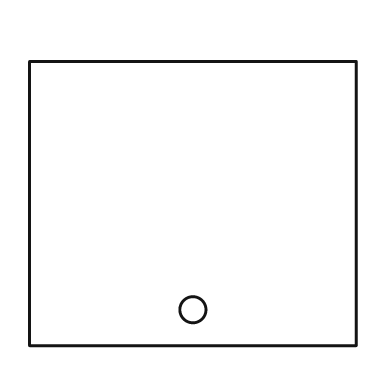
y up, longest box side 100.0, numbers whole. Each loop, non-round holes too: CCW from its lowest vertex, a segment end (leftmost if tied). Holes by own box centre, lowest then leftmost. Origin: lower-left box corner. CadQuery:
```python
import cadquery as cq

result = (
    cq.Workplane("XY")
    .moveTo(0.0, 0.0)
    .lineTo(100.0, 0.0)
    .lineTo(100.0, 87.0)
    .lineTo(0.0, 87.0)
    .close()
    .moveTo(50.0, 11.0)
    .circle(4.0)
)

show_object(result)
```